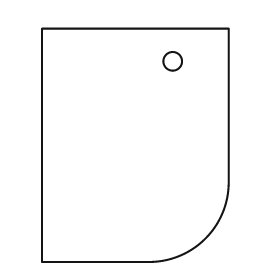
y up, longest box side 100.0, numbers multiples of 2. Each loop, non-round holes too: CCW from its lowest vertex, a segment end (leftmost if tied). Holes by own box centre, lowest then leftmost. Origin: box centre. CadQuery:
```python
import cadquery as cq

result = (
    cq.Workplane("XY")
    .moveTo(-40.0, -50.0)
    .lineTo(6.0, -50.0)
    .threePointArc((30.0, -40.0), (40.0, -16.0))
    .lineTo(40.0, 50.0)
    .lineTo(-40.0, 50.0)
    .close()
    .moveTo(16.0, 36.0)
    .circle(4.0)
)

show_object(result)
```